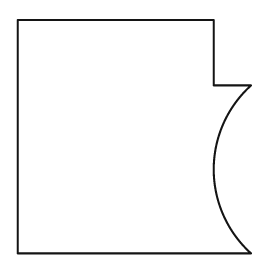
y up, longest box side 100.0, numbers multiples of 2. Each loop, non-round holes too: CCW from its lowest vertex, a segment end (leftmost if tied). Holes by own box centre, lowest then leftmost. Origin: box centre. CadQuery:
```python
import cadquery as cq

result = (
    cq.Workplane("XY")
    .moveTo(-50.0, -50.0)
    .lineTo(50.0, -50.0)
    .threePointArc((34.0, -14.0), (50.0, 22.0))
    .lineTo(34.0, 22.0)
    .lineTo(34.0, 50.0)
    .lineTo(-50.0, 50.0)
    .close()
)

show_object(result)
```